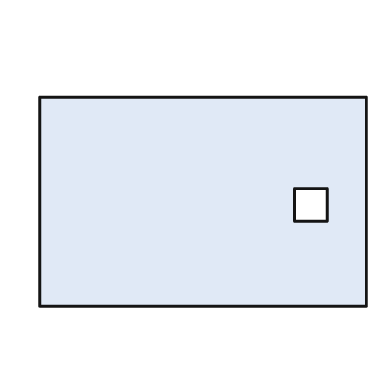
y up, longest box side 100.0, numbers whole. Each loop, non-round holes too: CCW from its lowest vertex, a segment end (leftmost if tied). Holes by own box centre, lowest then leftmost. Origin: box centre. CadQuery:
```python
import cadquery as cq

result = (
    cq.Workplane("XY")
    .moveTo(-50.0, -32.0)
    .lineTo(50.0, -32.0)
    .lineTo(50.0, 32.0)
    .lineTo(-50.0, 32.0)
    .close()
    .moveTo(28.0, -6.0)
    .lineTo(38.0, -6.0)
    .lineTo(38.0, 4.0)
    .lineTo(28.0, 4.0)
    .close()
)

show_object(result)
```